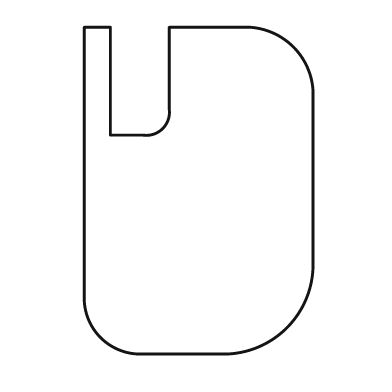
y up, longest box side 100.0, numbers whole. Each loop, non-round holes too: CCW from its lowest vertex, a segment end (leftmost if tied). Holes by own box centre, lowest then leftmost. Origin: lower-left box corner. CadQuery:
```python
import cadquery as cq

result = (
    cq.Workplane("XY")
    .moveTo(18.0, 0.0)
    .lineTo(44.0, 0.0)
    .threePointArc((62.0, 8.0), (70.0, 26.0))
    .lineTo(70.0, 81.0)
    .threePointArc((64.0, 94.0), (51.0, 100.0))
    .lineTo(26.0, 100.0)
    .lineTo(26.0, 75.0)
    .threePointArc((24.0, 69.0), (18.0, 67.0))
    .lineTo(8.0, 67.0)
    .lineTo(8.0, 100.0)
    .lineTo(0.0, 100.0)
    .lineTo(0.0, 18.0)
    .threePointArc((5.0, 5.0), (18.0, 0.0))
    .close()
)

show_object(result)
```